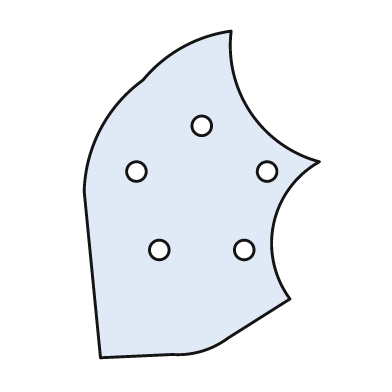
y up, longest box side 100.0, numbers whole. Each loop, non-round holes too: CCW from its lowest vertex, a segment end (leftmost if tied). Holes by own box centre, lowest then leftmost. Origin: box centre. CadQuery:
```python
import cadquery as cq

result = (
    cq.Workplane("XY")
    .moveTo(-31.0, -50.0)
    .lineTo(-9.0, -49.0)
    .threePointArc((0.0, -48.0), (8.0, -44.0))
    .lineTo(27.0, -32.0)
    .threePointArc((22.0, -9.0), (36.0, 10.0))
    .threePointArc((15.0, 25.0), (9.0, 50.0))
    .threePointArc((-6.0, 45.0), (-18.0, 35.0))
    .threePointArc((-31.0, 20.0), (-36.0, 1.0))
    .close()
    .moveTo(-13.0, -17.0)
    .circle(3.0)
    .moveTo(13.0, -17.0)
    .circle(3.0)
    .moveTo(-20.0, 7.0)
    .circle(3.0)
    .moveTo(20.0, 7.0)
    .circle(3.0)
    .moveTo(0.0, 21.0)
    .circle(3.0)
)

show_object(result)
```